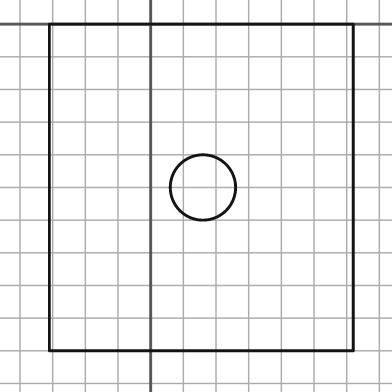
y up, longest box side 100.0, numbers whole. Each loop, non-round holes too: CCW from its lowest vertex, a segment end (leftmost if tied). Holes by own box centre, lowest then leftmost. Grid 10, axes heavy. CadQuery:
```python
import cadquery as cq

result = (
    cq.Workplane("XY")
    .moveTo(-31.0, -100.0)
    .lineTo(62.0, -100.0)
    .lineTo(62.0, 0.0)
    .lineTo(-31.0, 0.0)
    .close()
    .moveTo(16.0, -50.0)
    .circle(10.0)
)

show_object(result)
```